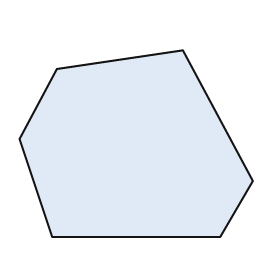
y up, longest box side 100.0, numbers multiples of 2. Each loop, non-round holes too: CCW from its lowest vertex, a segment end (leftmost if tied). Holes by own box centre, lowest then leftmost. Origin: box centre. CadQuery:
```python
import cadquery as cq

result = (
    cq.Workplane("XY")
    .moveTo(-36.0, -40.0)
    .lineTo(36.0, -40.0)
    .lineTo(50.0, -16.0)
    .lineTo(20.0, 40.0)
    .lineTo(-34.0, 32.0)
    .lineTo(-50.0, 2.0)
    .close()
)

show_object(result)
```